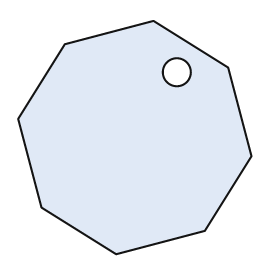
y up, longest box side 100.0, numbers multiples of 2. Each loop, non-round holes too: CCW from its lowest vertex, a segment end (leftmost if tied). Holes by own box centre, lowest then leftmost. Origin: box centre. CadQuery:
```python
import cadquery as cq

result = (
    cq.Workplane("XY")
    .moveTo(-8.0, -50.0)
    .lineTo(30.0, -40.0)
    .lineTo(50.0, -8.0)
    .lineTo(40.0, 30.0)
    .lineTo(8.0, 50.0)
    .lineTo(-30.0, 40.0)
    .lineTo(-50.0, 8.0)
    .lineTo(-40.0, -30.0)
    .close()
    .moveTo(18.0, 28.0)
    .circle(6.0)
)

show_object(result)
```